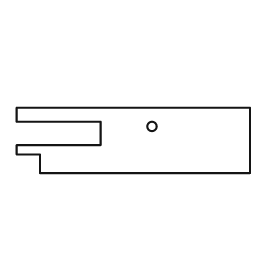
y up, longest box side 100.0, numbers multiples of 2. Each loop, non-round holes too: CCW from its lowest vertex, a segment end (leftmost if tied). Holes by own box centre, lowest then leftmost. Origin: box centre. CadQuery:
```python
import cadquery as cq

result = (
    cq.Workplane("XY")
    .moveTo(-40.0, -14.0)
    .lineTo(50.0, -14.0)
    .lineTo(50.0, 14.0)
    .lineTo(-50.0, 14.0)
    .lineTo(-50.0, 8.0)
    .lineTo(-14.0, 8.0)
    .lineTo(-14.0, -2.0)
    .lineTo(-50.0, -2.0)
    .lineTo(-50.0, -6.0)
    .lineTo(-40.0, -6.0)
    .close()
    .moveTo(8.0, 6.0)
    .circle(2.0)
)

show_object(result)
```